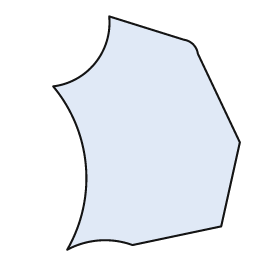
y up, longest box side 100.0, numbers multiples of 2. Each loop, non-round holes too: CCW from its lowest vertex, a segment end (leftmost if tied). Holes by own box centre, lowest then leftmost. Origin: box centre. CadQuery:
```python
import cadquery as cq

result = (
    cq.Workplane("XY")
    .moveTo(-34.0, -50.0)
    .threePointArc((-20.0, -46.0), (-6.0, -48.0))
    .lineTo(32.0, -40.0)
    .lineTo(40.0, -4.0)
    .lineTo(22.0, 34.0)
    .threePointArc((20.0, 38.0), (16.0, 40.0))
    .lineTo(-16.0, 50.0)
    .threePointArc((-22.0, 30.0), (-40.0, 20.0))
    .threePointArc((-26.0, -14.0), (-34.0, -50.0))
    .close()
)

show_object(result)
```